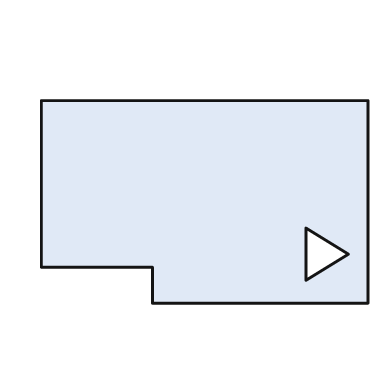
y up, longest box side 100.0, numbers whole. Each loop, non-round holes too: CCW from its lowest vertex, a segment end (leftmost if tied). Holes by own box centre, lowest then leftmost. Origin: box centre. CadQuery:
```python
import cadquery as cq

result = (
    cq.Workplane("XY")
    .moveTo(-16.0, -31.0)
    .lineTo(50.0, -31.0)
    .lineTo(50.0, 31.0)
    .lineTo(-50.0, 31.0)
    .lineTo(-50.0, -20.0)
    .lineTo(-16.0, -20.0)
    .close()
    .moveTo(31.0, -24.0)
    .lineTo(44.0, -16.0)
    .lineTo(31.0, -8.0)
    .close()
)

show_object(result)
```